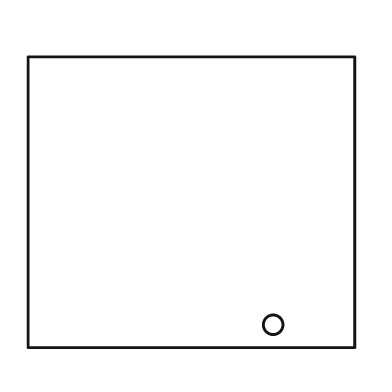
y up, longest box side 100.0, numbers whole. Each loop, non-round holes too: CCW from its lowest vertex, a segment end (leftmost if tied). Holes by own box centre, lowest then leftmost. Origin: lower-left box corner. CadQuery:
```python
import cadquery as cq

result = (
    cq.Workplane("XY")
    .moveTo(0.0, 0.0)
    .lineTo(100.0, 0.0)
    .lineTo(100.0, 89.0)
    .lineTo(0.0, 89.0)
    .close()
    .moveTo(75.0, 7.0)
    .circle(3.0)
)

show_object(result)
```